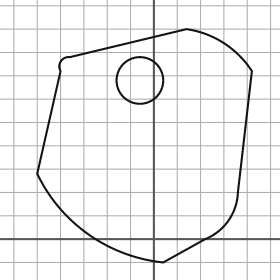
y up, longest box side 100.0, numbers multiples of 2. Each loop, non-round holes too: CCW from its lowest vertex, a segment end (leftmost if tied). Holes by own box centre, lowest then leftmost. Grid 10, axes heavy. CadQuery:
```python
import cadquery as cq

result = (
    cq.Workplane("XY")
    .moveTo(4.0, -10.0)
    .lineTo(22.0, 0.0)
    .threePointArc((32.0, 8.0), (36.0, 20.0))
    .lineTo(42.0, 72.0)
    .threePointArc((30.0, 84.0), (14.0, 90.0))
    .lineTo(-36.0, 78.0)
    .threePointArc((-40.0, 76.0), (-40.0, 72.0))
    .lineTo(-50.0, 28.0)
    .threePointArc((-28.0, 2.0), (4.0, -10.0))
    .close()
    .moveTo(-6.0, 68.0)
    .circle(10.0)
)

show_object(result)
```